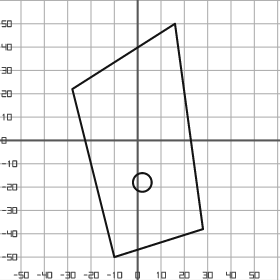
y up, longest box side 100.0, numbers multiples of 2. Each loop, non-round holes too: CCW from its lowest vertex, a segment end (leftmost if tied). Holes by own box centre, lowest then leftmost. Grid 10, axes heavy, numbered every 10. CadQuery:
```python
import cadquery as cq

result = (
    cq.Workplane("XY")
    .moveTo(-10.0, -50.0)
    .lineTo(28.0, -38.0)
    .lineTo(16.0, 50.0)
    .lineTo(-28.0, 22.0)
    .close()
    .moveTo(2.0, -18.0)
    .circle(4.0)
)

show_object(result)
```